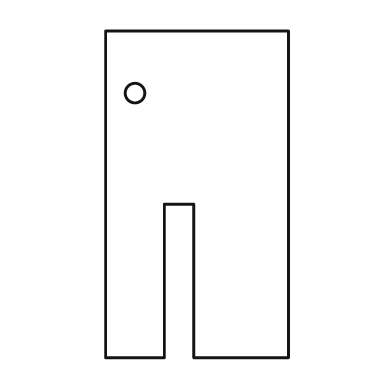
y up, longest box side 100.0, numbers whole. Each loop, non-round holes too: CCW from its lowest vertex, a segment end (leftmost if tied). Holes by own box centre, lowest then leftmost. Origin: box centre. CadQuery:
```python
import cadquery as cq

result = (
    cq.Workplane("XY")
    .moveTo(-28.0, -50.0)
    .lineTo(-10.0, -50.0)
    .lineTo(-10.0, -3.0)
    .lineTo(-1.0, -3.0)
    .lineTo(-1.0, -50.0)
    .lineTo(28.0, -50.0)
    .lineTo(28.0, 50.0)
    .lineTo(-28.0, 50.0)
    .close()
    .moveTo(-19.0, 31.0)
    .circle(3.0)
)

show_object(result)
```